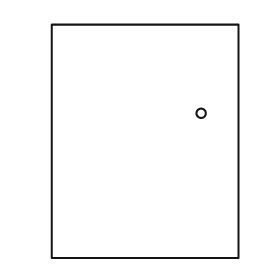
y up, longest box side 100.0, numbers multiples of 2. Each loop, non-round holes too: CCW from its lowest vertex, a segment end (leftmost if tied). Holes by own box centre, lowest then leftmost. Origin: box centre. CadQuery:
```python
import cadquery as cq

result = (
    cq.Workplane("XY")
    .moveTo(-40.0, -50.0)
    .lineTo(40.0, -50.0)
    .lineTo(40.0, 50.0)
    .lineTo(-40.0, 50.0)
    .close()
    .moveTo(24.0, 12.0)
    .circle(2.0)
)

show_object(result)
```